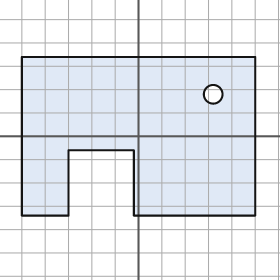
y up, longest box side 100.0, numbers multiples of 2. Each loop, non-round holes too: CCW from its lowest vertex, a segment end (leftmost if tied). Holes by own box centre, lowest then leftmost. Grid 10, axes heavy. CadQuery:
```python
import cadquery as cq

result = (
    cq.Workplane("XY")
    .moveTo(-50.0, -34.0)
    .lineTo(-30.0, -34.0)
    .lineTo(-30.0, -6.0)
    .lineTo(-2.0, -6.0)
    .lineTo(-2.0, -34.0)
    .lineTo(50.0, -34.0)
    .lineTo(50.0, 34.0)
    .lineTo(-50.0, 34.0)
    .close()
    .moveTo(32.0, 18.0)
    .circle(4.0)
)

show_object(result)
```